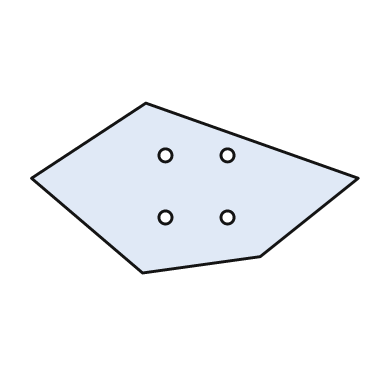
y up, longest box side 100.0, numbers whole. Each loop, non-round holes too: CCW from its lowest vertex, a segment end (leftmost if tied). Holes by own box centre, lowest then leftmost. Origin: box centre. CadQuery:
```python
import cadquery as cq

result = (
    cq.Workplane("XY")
    .moveTo(-16.0, -26.0)
    .lineTo(20.0, -21.0)
    .lineTo(50.0, 3.0)
    .lineTo(-15.0, 26.0)
    .lineTo(-50.0, 3.0)
    .close()
    .moveTo(-9.0, -9.0)
    .circle(2.0)
    .moveTo(10.0, -9.0)
    .circle(2.0)
    .moveTo(-9.0, 10.0)
    .circle(2.0)
    .moveTo(10.0, 10.0)
    .circle(2.0)
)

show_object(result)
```